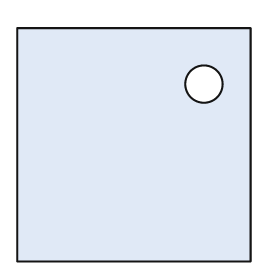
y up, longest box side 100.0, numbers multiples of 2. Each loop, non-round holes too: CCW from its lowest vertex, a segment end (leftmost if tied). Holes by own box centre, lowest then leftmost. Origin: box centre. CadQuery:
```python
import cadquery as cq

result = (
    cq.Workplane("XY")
    .moveTo(-50.0, -50.0)
    .lineTo(50.0, -50.0)
    .lineTo(50.0, 50.0)
    .lineTo(-50.0, 50.0)
    .close()
    .moveTo(30.0, 26.0)
    .circle(8.0)
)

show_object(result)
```